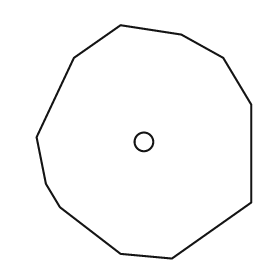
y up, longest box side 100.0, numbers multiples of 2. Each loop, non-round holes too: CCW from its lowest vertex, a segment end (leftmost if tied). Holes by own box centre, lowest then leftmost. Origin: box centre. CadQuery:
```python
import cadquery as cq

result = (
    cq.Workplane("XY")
    .moveTo(12.0, -50.0)
    .lineTo(46.0, -26.0)
    .lineTo(46.0, 16.0)
    .lineTo(34.0, 36.0)
    .lineTo(16.0, 46.0)
    .lineTo(-10.0, 50.0)
    .lineTo(-30.0, 36.0)
    .lineTo(-46.0, 2.0)
    .lineTo(-42.0, -18.0)
    .lineTo(-36.0, -28.0)
    .lineTo(-10.0, -48.0)
    .close()
    .moveTo(0.0, 0.0)
    .circle(4.0)
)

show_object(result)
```